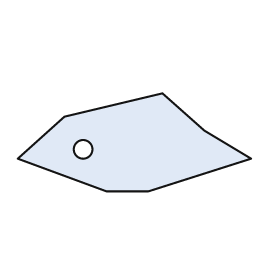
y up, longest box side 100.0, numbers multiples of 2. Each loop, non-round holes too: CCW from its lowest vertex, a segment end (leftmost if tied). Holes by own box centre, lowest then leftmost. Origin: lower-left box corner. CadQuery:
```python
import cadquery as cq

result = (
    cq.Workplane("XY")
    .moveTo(38.0, 0.0)
    .lineTo(56.0, 0.0)
    .lineTo(100.0, 14.0)
    .lineTo(80.0, 26.0)
    .lineTo(62.0, 42.0)
    .lineTo(20.0, 32.0)
    .lineTo(0.0, 14.0)
    .close()
    .moveTo(28.0, 18.0)
    .circle(4.0)
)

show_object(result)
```